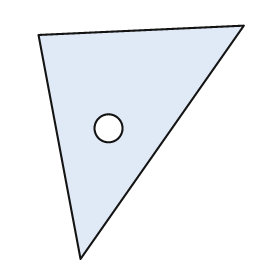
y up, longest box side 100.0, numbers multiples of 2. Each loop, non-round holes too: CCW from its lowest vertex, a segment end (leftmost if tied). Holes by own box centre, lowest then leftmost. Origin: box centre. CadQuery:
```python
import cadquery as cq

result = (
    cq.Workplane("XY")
    .moveTo(-26.0, -50.0)
    .lineTo(44.0, 50.0)
    .lineTo(-44.0, 46.0)
    .close()
    .moveTo(-14.0, 6.0)
    .circle(6.0)
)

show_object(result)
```